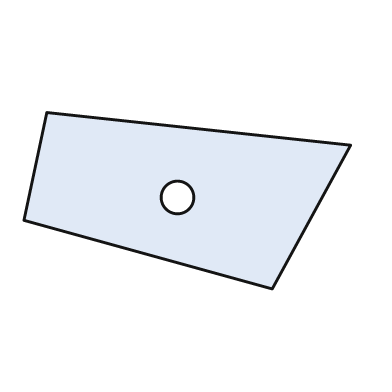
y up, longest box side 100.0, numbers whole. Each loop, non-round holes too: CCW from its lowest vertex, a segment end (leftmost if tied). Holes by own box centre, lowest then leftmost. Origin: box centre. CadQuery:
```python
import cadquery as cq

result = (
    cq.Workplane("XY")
    .moveTo(26.0, -27.0)
    .lineTo(50.0, 17.0)
    .lineTo(-43.0, 27.0)
    .lineTo(-50.0, -6.0)
    .close()
    .moveTo(-3.0, 1.0)
    .circle(5.0)
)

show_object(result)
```